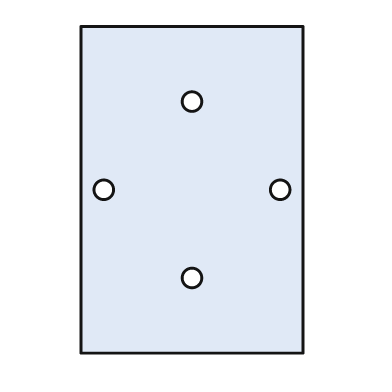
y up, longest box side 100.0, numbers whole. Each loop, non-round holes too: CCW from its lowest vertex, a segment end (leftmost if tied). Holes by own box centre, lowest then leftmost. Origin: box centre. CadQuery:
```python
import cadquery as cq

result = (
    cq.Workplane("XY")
    .moveTo(-34.0, -50.0)
    .lineTo(34.0, -50.0)
    .lineTo(34.0, 50.0)
    .lineTo(-34.0, 50.0)
    .close()
    .moveTo(0.0, -27.0)
    .circle(3.0)
    .moveTo(-27.0, 0.0)
    .circle(3.0)
    .moveTo(27.0, 0.0)
    .circle(3.0)
    .moveTo(0.0, 27.0)
    .circle(3.0)
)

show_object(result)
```